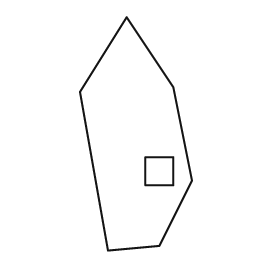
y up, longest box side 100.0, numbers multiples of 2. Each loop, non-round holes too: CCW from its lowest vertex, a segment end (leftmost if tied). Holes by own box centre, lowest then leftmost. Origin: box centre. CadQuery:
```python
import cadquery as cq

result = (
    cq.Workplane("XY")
    .moveTo(-12.0, -50.0)
    .lineTo(10.0, -48.0)
    .lineTo(24.0, -20.0)
    .lineTo(16.0, 20.0)
    .lineTo(-4.0, 50.0)
    .lineTo(-24.0, 18.0)
    .close()
    .moveTo(4.0, -22.0)
    .lineTo(16.0, -22.0)
    .lineTo(16.0, -10.0)
    .lineTo(4.0, -10.0)
    .close()
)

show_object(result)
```